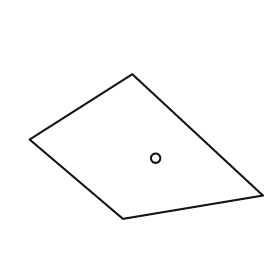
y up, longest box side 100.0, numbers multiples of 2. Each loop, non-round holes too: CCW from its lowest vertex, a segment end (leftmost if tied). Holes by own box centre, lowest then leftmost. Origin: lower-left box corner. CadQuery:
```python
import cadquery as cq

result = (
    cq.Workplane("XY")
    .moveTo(40.0, 0.0)
    .lineTo(100.0, 10.0)
    .lineTo(44.0, 62.0)
    .lineTo(0.0, 34.0)
    .close()
    .moveTo(54.0, 26.0)
    .circle(2.0)
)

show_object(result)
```